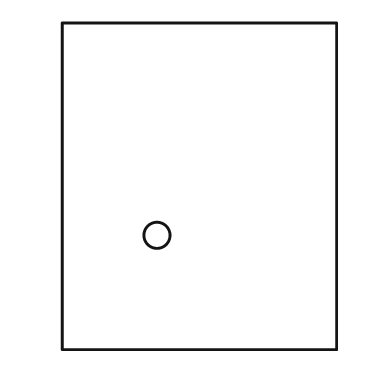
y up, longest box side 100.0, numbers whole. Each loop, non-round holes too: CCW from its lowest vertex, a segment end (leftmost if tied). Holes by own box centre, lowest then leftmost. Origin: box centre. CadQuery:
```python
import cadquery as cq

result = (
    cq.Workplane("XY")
    .moveTo(-42.0, -50.0)
    .lineTo(42.0, -50.0)
    .lineTo(42.0, 50.0)
    .lineTo(-42.0, 50.0)
    .close()
    .moveTo(-13.0, -15.0)
    .circle(4.0)
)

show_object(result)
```